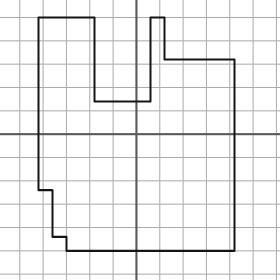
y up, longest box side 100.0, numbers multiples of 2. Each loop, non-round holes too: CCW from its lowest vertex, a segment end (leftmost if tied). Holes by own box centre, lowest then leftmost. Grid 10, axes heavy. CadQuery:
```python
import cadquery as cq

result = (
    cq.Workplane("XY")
    .moveTo(-30.0, -50.0)
    .lineTo(42.0, -50.0)
    .lineTo(42.0, 32.0)
    .lineTo(12.0, 32.0)
    .lineTo(12.0, 50.0)
    .lineTo(6.0, 50.0)
    .lineTo(6.0, 14.0)
    .lineTo(-18.0, 14.0)
    .lineTo(-18.0, 50.0)
    .lineTo(-42.0, 50.0)
    .lineTo(-42.0, -24.0)
    .lineTo(-36.0, -24.0)
    .lineTo(-36.0, -44.0)
    .lineTo(-30.0, -44.0)
    .close()
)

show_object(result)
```